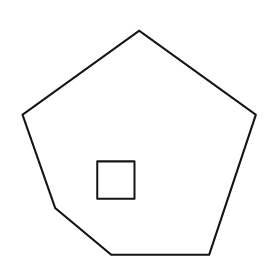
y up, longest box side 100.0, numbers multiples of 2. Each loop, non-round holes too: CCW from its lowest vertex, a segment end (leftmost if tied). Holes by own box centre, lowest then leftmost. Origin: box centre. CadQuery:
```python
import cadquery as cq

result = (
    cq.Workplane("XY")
    .moveTo(-12.0, -48.0)
    .lineTo(30.0, -48.0)
    .lineTo(50.0, 12.0)
    .lineTo(0.0, 48.0)
    .lineTo(-50.0, 12.0)
    .lineTo(-36.0, -28.0)
    .close()
    .moveTo(-18.0, -24.0)
    .lineTo(-2.0, -24.0)
    .lineTo(-2.0, -8.0)
    .lineTo(-18.0, -8.0)
    .close()
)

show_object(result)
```